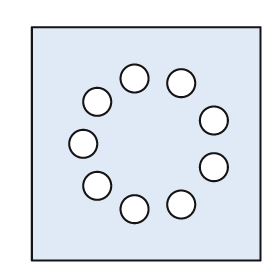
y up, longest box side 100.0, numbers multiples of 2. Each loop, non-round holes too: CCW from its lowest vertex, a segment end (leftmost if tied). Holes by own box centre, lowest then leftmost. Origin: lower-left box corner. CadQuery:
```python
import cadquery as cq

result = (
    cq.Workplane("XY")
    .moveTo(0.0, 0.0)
    .lineTo(98.0, 0.0)
    .lineTo(98.0, 100.0)
    .lineTo(0.0, 100.0)
    .close()
    .moveTo(44.0, 22.0)
    .circle(6.0)
    .moveTo(64.0, 24.0)
    .circle(6.0)
    .moveTo(28.0, 32.0)
    .circle(6.0)
    .moveTo(78.0, 40.0)
    .circle(6.0)
    .moveTo(22.0, 50.0)
    .circle(6.0)
    .moveTo(78.0, 60.0)
    .circle(6.0)
    .moveTo(28.0, 68.0)
    .circle(6.0)
    .moveTo(64.0, 76.0)
    .circle(6.0)
    .moveTo(44.0, 78.0)
    .circle(6.0)
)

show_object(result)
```